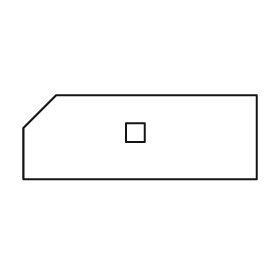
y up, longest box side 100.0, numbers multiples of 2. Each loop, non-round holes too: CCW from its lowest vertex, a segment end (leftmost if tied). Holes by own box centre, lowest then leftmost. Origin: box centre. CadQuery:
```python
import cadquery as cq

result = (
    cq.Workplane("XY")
    .moveTo(-50.0, -18.0)
    .lineTo(50.0, -18.0)
    .lineTo(50.0, 18.0)
    .lineTo(-36.0, 18.0)
    .lineTo(-50.0, 4.0)
    .close()
    .moveTo(-6.0, -2.0)
    .lineTo(2.0, -2.0)
    .lineTo(2.0, 6.0)
    .lineTo(-6.0, 6.0)
    .close()
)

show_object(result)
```